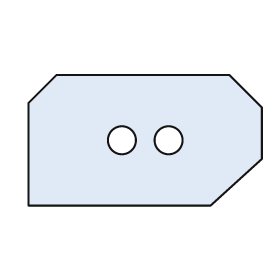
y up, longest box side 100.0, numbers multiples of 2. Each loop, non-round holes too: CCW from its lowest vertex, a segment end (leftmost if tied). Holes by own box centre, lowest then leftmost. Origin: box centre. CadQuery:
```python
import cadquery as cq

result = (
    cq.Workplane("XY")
    .moveTo(-50.0, -28.0)
    .lineTo(28.0, -28.0)
    .lineTo(50.0, -8.0)
    .lineTo(50.0, 14.0)
    .lineTo(36.0, 28.0)
    .lineTo(-38.0, 28.0)
    .lineTo(-50.0, 16.0)
    .close()
    .moveTo(-10.0, 0.0)
    .circle(6.0)
    .moveTo(10.0, 0.0)
    .circle(6.0)
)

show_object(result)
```